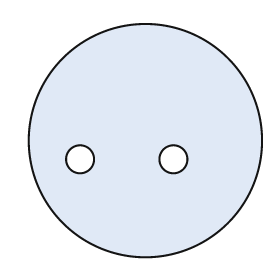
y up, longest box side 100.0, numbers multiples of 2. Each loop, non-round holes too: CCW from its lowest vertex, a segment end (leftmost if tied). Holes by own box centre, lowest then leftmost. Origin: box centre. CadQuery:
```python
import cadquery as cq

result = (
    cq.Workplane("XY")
    .moveTo(0.0, 0.0)
    .circle(50.0)
    .moveTo(-28.0, -8.0)
    .circle(6.0)
    .moveTo(12.0, -8.0)
    .circle(6.0)
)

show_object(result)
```